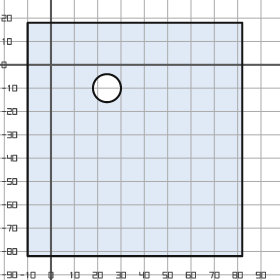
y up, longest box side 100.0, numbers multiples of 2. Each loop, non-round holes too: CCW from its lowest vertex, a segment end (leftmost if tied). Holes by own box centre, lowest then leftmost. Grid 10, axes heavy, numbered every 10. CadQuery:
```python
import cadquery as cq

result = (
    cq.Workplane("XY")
    .moveTo(-10.0, -82.0)
    .lineTo(82.0, -82.0)
    .lineTo(82.0, 18.0)
    .lineTo(-10.0, 18.0)
    .close()
    .moveTo(24.0, -10.0)
    .circle(6.0)
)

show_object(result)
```